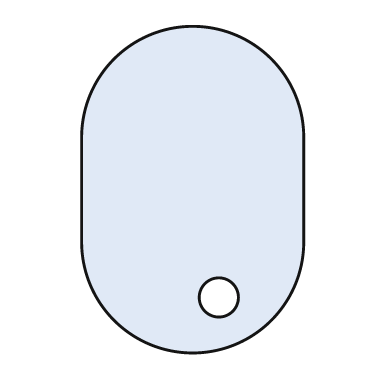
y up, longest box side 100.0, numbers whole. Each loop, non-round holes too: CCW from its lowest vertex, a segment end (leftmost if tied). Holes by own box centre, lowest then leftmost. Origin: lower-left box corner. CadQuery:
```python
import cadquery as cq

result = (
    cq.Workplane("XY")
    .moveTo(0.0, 34.0)
    .threePointArc((34.0, 0.0), (68.0, 34.0))
    .lineTo(68.0, 66.0)
    .threePointArc((34.0, 100.0), (0.0, 66.0))
    .close()
    .moveTo(42.0, 17.0)
    .circle(6.0)
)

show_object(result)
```